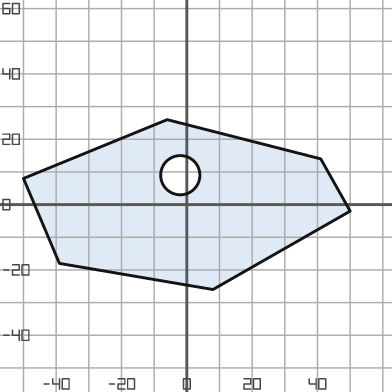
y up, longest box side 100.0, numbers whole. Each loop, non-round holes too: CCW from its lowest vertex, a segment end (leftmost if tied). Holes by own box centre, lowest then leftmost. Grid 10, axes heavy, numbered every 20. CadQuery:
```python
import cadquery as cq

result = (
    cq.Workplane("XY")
    .moveTo(8.0, -26.0)
    .lineTo(50.0, -2.0)
    .lineTo(41.0, 14.0)
    .lineTo(-6.0, 26.0)
    .lineTo(-50.0, 8.0)
    .lineTo(-39.0, -18.0)
    .close()
    .moveTo(-2.0, 9.0)
    .circle(6.0)
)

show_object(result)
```